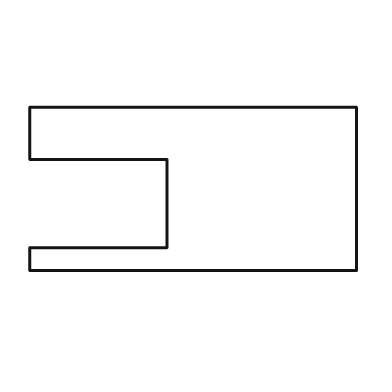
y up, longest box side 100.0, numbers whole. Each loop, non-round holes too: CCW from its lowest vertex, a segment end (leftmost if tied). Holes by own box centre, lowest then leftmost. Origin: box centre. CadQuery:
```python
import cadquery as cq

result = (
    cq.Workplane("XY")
    .moveTo(-50.0, -25.0)
    .lineTo(50.0, -25.0)
    .lineTo(50.0, 25.0)
    .lineTo(-50.0, 25.0)
    .lineTo(-50.0, 9.0)
    .lineTo(-8.0, 9.0)
    .lineTo(-8.0, -18.0)
    .lineTo(-50.0, -18.0)
    .close()
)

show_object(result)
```